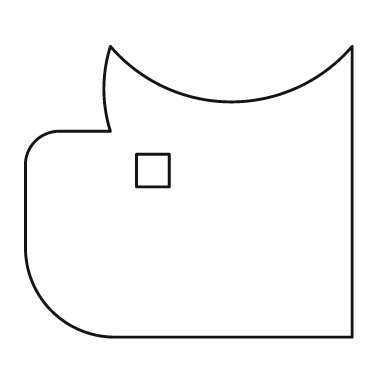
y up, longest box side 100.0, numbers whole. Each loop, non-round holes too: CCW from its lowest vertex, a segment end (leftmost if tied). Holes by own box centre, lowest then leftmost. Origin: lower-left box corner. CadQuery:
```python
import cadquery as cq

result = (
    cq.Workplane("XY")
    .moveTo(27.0, 0.0)
    .lineTo(100.0, 0.0)
    .lineTo(100.0, 89.0)
    .threePointArc((63.0, 72.0), (26.0, 89.0))
    .threePointArc((24.0, 76.0), (26.0, 63.0))
    .lineTo(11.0, 63.0)
    .threePointArc((3.0, 60.0), (0.0, 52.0))
    .lineTo(0.0, 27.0)
    .threePointArc((8.0, 8.0), (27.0, 0.0))
    .close()
    .moveTo(34.0, 46.0)
    .lineTo(44.0, 46.0)
    .lineTo(44.0, 56.0)
    .lineTo(34.0, 56.0)
    .close()
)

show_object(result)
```